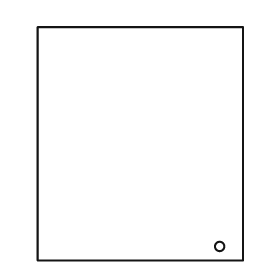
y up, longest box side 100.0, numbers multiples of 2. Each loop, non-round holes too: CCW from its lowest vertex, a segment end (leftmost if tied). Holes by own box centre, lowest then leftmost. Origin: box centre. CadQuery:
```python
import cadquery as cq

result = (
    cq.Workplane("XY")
    .moveTo(-44.0, -50.0)
    .lineTo(44.0, -50.0)
    .lineTo(44.0, 50.0)
    .lineTo(-44.0, 50.0)
    .close()
    .moveTo(34.0, -44.0)
    .circle(2.0)
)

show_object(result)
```